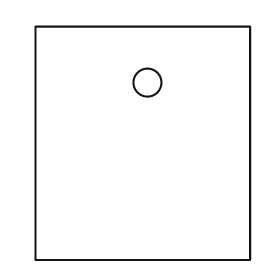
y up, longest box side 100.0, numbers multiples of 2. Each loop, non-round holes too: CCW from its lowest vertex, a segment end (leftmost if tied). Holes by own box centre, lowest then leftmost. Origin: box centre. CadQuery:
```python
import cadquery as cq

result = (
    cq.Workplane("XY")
    .moveTo(-46.0, -50.0)
    .lineTo(46.0, -50.0)
    .lineTo(46.0, 50.0)
    .lineTo(-46.0, 50.0)
    .close()
    .moveTo(2.0, 26.0)
    .circle(6.0)
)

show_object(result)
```